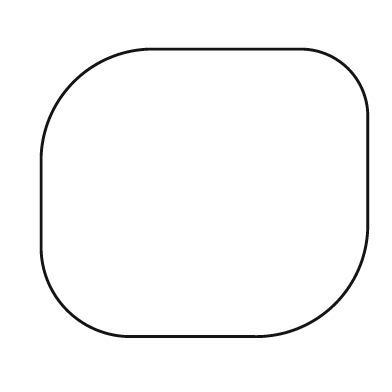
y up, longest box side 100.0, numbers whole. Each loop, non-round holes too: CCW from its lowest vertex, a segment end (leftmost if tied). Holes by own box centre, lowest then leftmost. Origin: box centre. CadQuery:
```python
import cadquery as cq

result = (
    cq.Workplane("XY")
    .moveTo(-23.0, -44.0)
    .lineTo(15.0, -44.0)
    .threePointArc((40.0, -34.0), (50.0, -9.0))
    .lineTo(50.0, 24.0)
    .threePointArc((44.0, 38.0), (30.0, 44.0))
    .lineTo(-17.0, 44.0)
    .threePointArc((-40.0, 34.0), (-50.0, 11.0))
    .lineTo(-50.0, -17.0)
    .threePointArc((-42.0, -36.0), (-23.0, -44.0))
    .close()
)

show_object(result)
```